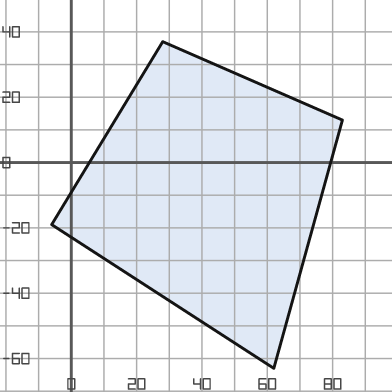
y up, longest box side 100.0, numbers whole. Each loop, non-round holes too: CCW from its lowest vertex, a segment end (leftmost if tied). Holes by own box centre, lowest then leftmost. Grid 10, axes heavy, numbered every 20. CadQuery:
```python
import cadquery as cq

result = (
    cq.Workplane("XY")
    .moveTo(62.0, -63.0)
    .lineTo(83.0, 13.0)
    .lineTo(28.0, 37.0)
    .lineTo(-6.0, -19.0)
    .close()
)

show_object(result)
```